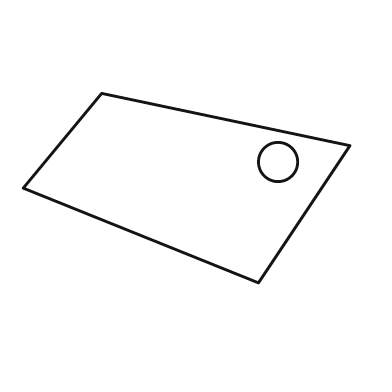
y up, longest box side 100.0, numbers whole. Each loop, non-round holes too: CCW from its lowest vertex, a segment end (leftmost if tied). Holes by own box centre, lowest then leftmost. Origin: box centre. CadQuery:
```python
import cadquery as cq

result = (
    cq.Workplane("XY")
    .moveTo(22.0, -29.0)
    .lineTo(50.0, 13.0)
    .lineTo(-26.0, 29.0)
    .lineTo(-50.0, 0.0)
    .close()
    .moveTo(28.0, 8.0)
    .circle(6.0)
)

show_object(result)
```